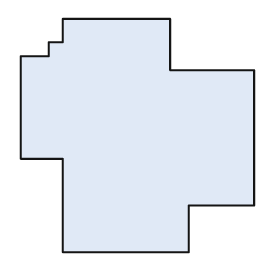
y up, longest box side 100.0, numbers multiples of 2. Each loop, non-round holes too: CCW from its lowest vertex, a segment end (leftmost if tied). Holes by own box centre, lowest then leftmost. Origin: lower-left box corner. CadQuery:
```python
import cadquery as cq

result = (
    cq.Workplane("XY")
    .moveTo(18.0, 0.0)
    .lineTo(72.0, 0.0)
    .lineTo(72.0, 20.0)
    .lineTo(100.0, 20.0)
    .lineTo(100.0, 78.0)
    .lineTo(64.0, 78.0)
    .lineTo(64.0, 100.0)
    .lineTo(18.0, 100.0)
    .lineTo(18.0, 90.0)
    .lineTo(12.0, 90.0)
    .lineTo(12.0, 84.0)
    .lineTo(0.0, 84.0)
    .lineTo(0.0, 40.0)
    .lineTo(18.0, 40.0)
    .close()
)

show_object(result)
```